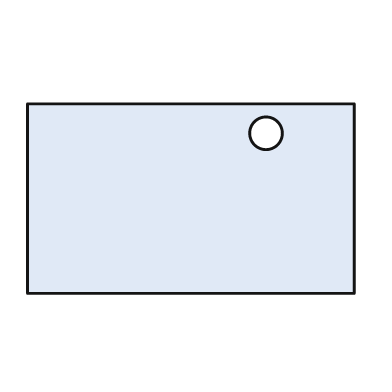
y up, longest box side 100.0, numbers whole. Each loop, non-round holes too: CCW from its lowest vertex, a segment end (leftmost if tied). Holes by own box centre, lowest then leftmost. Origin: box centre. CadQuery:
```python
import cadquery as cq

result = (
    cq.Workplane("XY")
    .moveTo(-50.0, -29.0)
    .lineTo(50.0, -29.0)
    .lineTo(50.0, 29.0)
    .lineTo(-50.0, 29.0)
    .close()
    .moveTo(23.0, 20.0)
    .circle(5.0)
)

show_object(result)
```